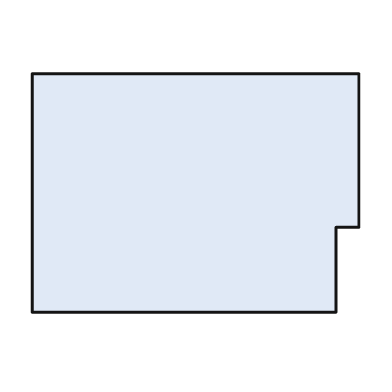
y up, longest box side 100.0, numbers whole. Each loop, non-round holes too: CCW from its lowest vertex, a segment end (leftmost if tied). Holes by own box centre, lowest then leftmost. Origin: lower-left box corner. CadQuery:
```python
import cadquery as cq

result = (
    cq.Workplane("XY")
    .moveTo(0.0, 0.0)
    .lineTo(93.0, 0.0)
    .lineTo(93.0, 26.0)
    .lineTo(100.0, 26.0)
    .lineTo(100.0, 73.0)
    .lineTo(0.0, 73.0)
    .close()
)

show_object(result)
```